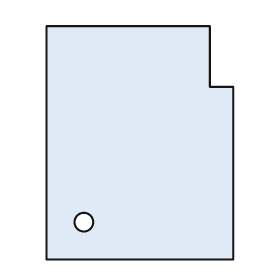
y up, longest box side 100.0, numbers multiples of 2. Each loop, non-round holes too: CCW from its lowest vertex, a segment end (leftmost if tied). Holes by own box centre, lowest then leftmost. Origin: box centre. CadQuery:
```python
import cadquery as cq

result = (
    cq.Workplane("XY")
    .moveTo(-40.0, -50.0)
    .lineTo(40.0, -50.0)
    .lineTo(40.0, 24.0)
    .lineTo(30.0, 24.0)
    .lineTo(30.0, 50.0)
    .lineTo(-40.0, 50.0)
    .close()
    .moveTo(-24.0, -34.0)
    .circle(4.0)
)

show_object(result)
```